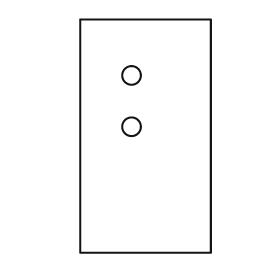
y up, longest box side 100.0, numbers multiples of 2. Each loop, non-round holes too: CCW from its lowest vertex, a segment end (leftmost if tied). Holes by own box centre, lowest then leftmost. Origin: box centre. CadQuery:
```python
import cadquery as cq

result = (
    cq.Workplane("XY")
    .moveTo(-28.0, -50.0)
    .lineTo(28.0, -50.0)
    .lineTo(28.0, 50.0)
    .lineTo(-28.0, 50.0)
    .close()
    .moveTo(-6.0, 4.0)
    .circle(4.0)
    .moveTo(-6.0, 26.0)
    .circle(4.0)
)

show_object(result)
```